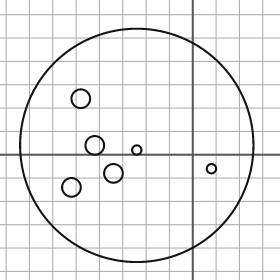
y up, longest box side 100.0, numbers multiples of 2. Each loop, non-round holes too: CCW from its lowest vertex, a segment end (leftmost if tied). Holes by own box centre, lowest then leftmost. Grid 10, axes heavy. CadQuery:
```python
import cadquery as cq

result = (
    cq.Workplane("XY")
    .moveTo(-24.0, 4.0)
    .circle(50.0)
    .moveTo(-52.0, -14.0)
    .circle(4.0)
    .moveTo(-34.0, -8.0)
    .circle(4.0)
    .moveTo(8.0, -6.0)
    .circle(2.0)
    .moveTo(-24.0, 2.0)
    .circle(2.0)
    .moveTo(-42.0, 4.0)
    .circle(4.0)
    .moveTo(-48.0, 24.0)
    .circle(4.0)
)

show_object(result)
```